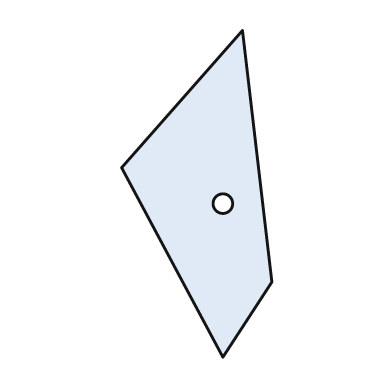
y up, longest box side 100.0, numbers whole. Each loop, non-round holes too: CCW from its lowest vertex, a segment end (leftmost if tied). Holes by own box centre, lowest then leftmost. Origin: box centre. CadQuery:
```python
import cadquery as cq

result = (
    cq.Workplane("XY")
    .moveTo(8.0, -50.0)
    .lineTo(23.0, -27.0)
    .lineTo(14.0, 50.0)
    .lineTo(-23.0, 8.0)
    .close()
    .moveTo(8.0, -3.0)
    .circle(3.0)
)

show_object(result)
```